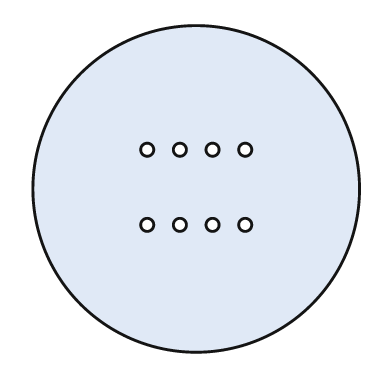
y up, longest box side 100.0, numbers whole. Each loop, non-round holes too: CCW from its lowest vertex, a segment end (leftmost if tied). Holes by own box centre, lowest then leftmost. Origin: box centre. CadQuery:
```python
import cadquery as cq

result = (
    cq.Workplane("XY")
    .moveTo(0.0, 0.0)
    .circle(50.0)
    .moveTo(-15.0, -11.0)
    .circle(2.0)
    .moveTo(-5.0, -11.0)
    .circle(2.0)
    .moveTo(5.0, -11.0)
    .circle(2.0)
    .moveTo(15.0, -11.0)
    .circle(2.0)
    .moveTo(-15.0, 12.0)
    .circle(2.0)
    .moveTo(-5.0, 12.0)
    .circle(2.0)
    .moveTo(5.0, 12.0)
    .circle(2.0)
    .moveTo(15.0, 12.0)
    .circle(2.0)
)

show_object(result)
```